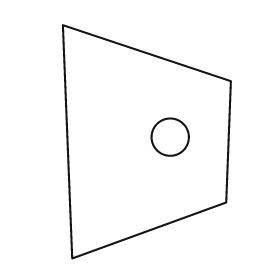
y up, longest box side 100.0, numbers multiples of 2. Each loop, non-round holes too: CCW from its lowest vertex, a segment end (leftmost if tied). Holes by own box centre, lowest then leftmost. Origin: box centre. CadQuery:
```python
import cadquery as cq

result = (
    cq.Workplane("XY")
    .moveTo(-32.0, -50.0)
    .lineTo(34.0, -26.0)
    .lineTo(36.0, 26.0)
    .lineTo(-36.0, 50.0)
    .close()
    .moveTo(10.0, 2.0)
    .circle(8.0)
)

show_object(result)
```